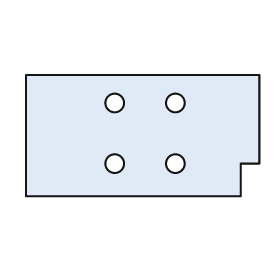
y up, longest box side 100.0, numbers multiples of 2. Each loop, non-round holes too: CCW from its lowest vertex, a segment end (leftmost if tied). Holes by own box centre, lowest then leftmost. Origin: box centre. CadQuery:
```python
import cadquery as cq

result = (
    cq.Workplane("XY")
    .moveTo(-50.0, -26.0)
    .lineTo(42.0, -26.0)
    .lineTo(42.0, -12.0)
    .lineTo(50.0, -12.0)
    .lineTo(50.0, 26.0)
    .lineTo(-50.0, 26.0)
    .close()
    .moveTo(-12.0, -12.0)
    .circle(4.0)
    .moveTo(14.0, -12.0)
    .circle(4.0)
    .moveTo(-12.0, 14.0)
    .circle(4.0)
    .moveTo(14.0, 14.0)
    .circle(4.0)
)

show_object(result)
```